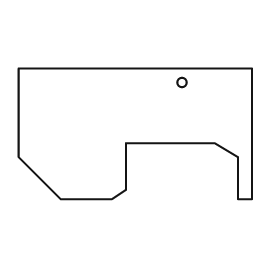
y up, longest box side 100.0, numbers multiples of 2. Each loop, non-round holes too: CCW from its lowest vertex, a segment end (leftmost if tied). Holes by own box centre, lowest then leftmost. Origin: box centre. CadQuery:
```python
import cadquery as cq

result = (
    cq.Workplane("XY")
    .moveTo(-32.0, -28.0)
    .lineTo(-10.0, -28.0)
    .lineTo(-4.0, -24.0)
    .lineTo(-4.0, -4.0)
    .lineTo(34.0, -4.0)
    .lineTo(44.0, -10.0)
    .lineTo(44.0, -28.0)
    .lineTo(50.0, -28.0)
    .lineTo(50.0, 28.0)
    .lineTo(-50.0, 28.0)
    .lineTo(-50.0, -10.0)
    .close()
    .moveTo(20.0, 22.0)
    .circle(2.0)
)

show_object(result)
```